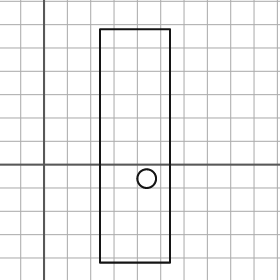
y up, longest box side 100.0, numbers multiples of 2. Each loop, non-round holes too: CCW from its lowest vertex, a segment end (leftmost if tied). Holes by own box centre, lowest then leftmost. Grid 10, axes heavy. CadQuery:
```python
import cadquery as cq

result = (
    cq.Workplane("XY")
    .moveTo(24.0, -42.0)
    .lineTo(54.0, -42.0)
    .lineTo(54.0, 58.0)
    .lineTo(24.0, 58.0)
    .close()
    .moveTo(44.0, -6.0)
    .circle(4.0)
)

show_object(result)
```